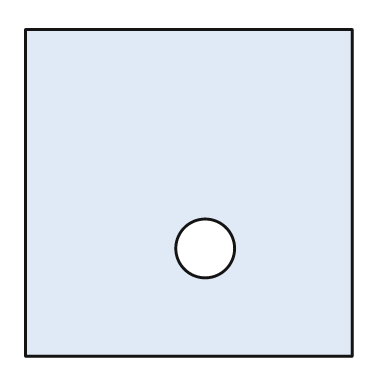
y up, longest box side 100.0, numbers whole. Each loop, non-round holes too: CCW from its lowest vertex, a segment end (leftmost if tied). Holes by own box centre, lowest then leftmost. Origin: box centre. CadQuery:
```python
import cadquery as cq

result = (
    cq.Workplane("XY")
    .moveTo(-50.0, -50.0)
    .lineTo(50.0, -50.0)
    .lineTo(50.0, 50.0)
    .lineTo(-50.0, 50.0)
    .close()
    .moveTo(5.0, -17.0)
    .circle(9.0)
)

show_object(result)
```